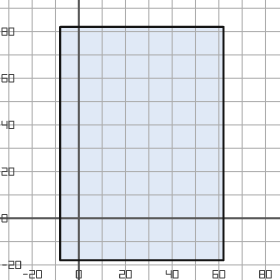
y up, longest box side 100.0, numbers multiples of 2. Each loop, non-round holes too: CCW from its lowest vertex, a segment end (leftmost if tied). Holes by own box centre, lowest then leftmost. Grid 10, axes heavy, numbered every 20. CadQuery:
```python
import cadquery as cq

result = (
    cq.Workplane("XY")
    .moveTo(-8.0, -18.0)
    .lineTo(62.0, -18.0)
    .lineTo(62.0, 82.0)
    .lineTo(-8.0, 82.0)
    .close()
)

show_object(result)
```